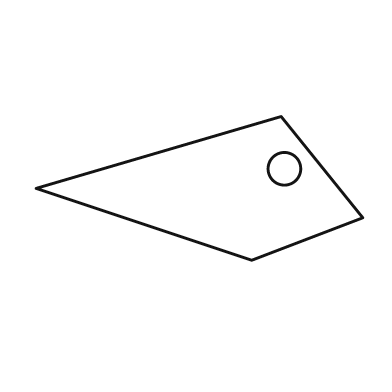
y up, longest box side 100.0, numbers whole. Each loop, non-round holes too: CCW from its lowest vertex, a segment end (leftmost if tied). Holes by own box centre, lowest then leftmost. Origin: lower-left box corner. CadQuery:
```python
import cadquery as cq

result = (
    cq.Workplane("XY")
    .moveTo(66.0, 0.0)
    .lineTo(100.0, 13.0)
    .lineTo(75.0, 44.0)
    .lineTo(0.0, 22.0)
    .close()
    .moveTo(76.0, 28.0)
    .circle(5.0)
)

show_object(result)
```